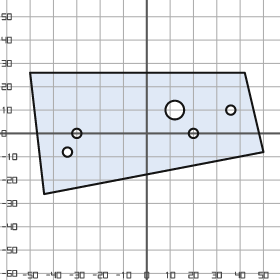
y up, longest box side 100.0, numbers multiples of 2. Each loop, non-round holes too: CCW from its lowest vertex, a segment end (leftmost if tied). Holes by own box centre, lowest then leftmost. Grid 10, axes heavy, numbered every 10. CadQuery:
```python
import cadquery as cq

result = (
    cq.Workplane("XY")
    .moveTo(-44.0, -26.0)
    .lineTo(50.0, -8.0)
    .lineTo(42.0, 26.0)
    .lineTo(-50.0, 26.0)
    .close()
    .moveTo(-34.0, -8.0)
    .circle(2.0)
    .moveTo(-30.0, 0.0)
    .circle(2.0)
    .moveTo(20.0, 0.0)
    .circle(2.0)
    .moveTo(12.0, 10.0)
    .circle(4.0)
    .moveTo(36.0, 10.0)
    .circle(2.0)
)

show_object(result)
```